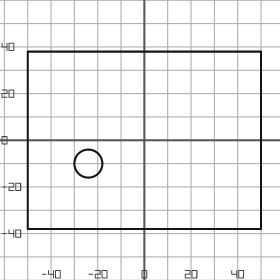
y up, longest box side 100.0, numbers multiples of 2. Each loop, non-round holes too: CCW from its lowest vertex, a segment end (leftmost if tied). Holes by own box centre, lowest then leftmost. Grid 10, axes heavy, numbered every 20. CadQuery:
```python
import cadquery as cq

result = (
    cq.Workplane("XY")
    .moveTo(-50.0, -38.0)
    .lineTo(50.0, -38.0)
    .lineTo(50.0, 38.0)
    .lineTo(-50.0, 38.0)
    .close()
    .moveTo(-24.0, -10.0)
    .circle(6.0)
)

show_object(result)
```